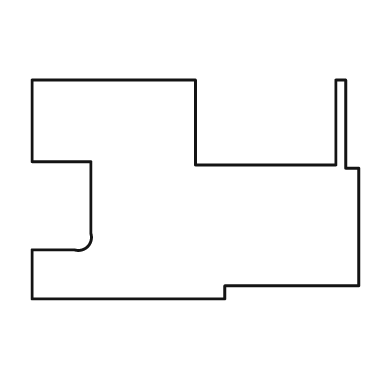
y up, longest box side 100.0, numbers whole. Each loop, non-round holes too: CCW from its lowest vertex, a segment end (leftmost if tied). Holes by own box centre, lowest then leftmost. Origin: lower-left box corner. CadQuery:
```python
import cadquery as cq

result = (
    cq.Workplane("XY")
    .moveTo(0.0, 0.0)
    .lineTo(59.0, 0.0)
    .lineTo(59.0, 4.0)
    .lineTo(100.0, 4.0)
    .lineTo(100.0, 40.0)
    .lineTo(96.0, 40.0)
    .lineTo(96.0, 67.0)
    .lineTo(93.0, 67.0)
    .lineTo(93.0, 41.0)
    .lineTo(50.0, 41.0)
    .lineTo(50.0, 67.0)
    .lineTo(0.0, 67.0)
    .lineTo(0.0, 42.0)
    .lineTo(18.0, 42.0)
    .lineTo(18.0, 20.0)
    .threePointArc((17.0, 16.0), (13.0, 15.0))
    .lineTo(0.0, 15.0)
    .close()
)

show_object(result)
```